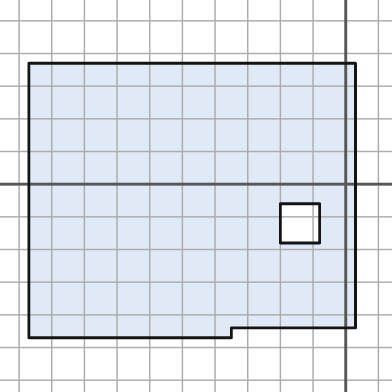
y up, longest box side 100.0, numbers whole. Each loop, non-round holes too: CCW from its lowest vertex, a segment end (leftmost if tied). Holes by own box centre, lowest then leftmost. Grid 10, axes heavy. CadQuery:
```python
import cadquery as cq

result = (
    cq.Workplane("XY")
    .moveTo(-97.0, -47.0)
    .lineTo(-35.0, -47.0)
    .lineTo(-35.0, -44.0)
    .lineTo(3.0, -44.0)
    .lineTo(3.0, 37.0)
    .lineTo(-97.0, 37.0)
    .close()
    .moveTo(-20.0, -18.0)
    .lineTo(-8.0, -18.0)
    .lineTo(-8.0, -6.0)
    .lineTo(-20.0, -6.0)
    .close()
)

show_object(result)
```